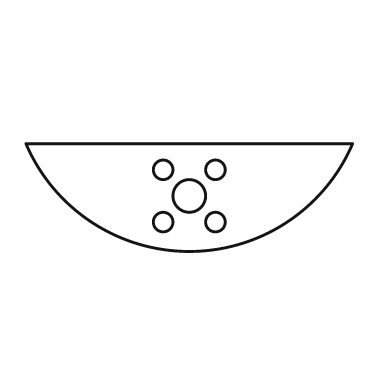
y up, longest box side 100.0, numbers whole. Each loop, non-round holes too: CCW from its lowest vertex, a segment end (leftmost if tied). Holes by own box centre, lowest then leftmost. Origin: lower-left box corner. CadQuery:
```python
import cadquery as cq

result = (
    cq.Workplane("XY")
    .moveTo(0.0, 33.0)
    .threePointArc((50.0, 0.0), (100.0, 33.0))
    .close()
    .moveTo(42.0, 9.0)
    .circle(3.0)
    .moveTo(58.0, 9.0)
    .circle(3.0)
    .moveTo(50.0, 17.0)
    .circle(5.0)
    .moveTo(42.0, 25.0)
    .circle(3.0)
    .moveTo(58.0, 25.0)
    .circle(3.0)
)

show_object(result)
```